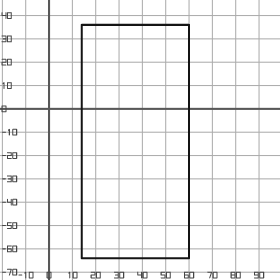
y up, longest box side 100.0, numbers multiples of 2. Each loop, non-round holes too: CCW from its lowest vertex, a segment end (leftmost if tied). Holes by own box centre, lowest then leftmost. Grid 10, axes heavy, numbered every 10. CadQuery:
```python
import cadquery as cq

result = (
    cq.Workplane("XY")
    .moveTo(14.0, -64.0)
    .lineTo(60.0, -64.0)
    .lineTo(60.0, 36.0)
    .lineTo(14.0, 36.0)
    .close()
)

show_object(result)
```